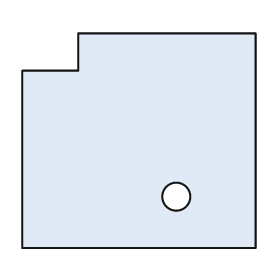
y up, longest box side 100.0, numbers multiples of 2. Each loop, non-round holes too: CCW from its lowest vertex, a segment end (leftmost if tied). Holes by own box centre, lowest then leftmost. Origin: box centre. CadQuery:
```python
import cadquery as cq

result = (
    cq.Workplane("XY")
    .moveTo(-50.0, -46.0)
    .lineTo(50.0, -46.0)
    .lineTo(50.0, 46.0)
    .lineTo(-26.0, 46.0)
    .lineTo(-26.0, 30.0)
    .lineTo(-50.0, 30.0)
    .close()
    .moveTo(16.0, -24.0)
    .circle(6.0)
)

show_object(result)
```